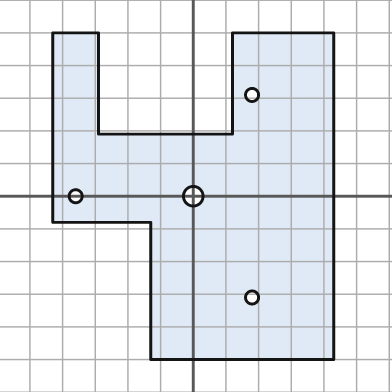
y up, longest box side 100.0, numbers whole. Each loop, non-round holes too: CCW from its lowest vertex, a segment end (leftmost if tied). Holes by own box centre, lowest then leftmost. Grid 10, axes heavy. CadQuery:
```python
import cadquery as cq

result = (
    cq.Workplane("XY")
    .moveTo(-13.0, -50.0)
    .lineTo(43.0, -50.0)
    .lineTo(43.0, 50.0)
    .lineTo(12.0, 50.0)
    .lineTo(12.0, 19.0)
    .lineTo(-29.0, 19.0)
    .lineTo(-29.0, 50.0)
    .lineTo(-43.0, 50.0)
    .lineTo(-43.0, -8.0)
    .lineTo(-13.0, -8.0)
    .close()
    .moveTo(18.0, -31.0)
    .circle(2.0)
    .moveTo(-36.0, 0.0)
    .circle(2.0)
    .moveTo(0.0, 0.0)
    .circle(3.0)
    .moveTo(18.0, 31.0)
    .circle(2.0)
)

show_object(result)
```